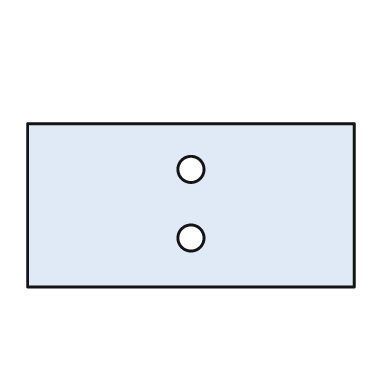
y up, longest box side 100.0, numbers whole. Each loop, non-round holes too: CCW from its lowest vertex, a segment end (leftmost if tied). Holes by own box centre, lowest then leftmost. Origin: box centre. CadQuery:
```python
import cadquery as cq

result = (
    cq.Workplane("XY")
    .moveTo(-50.0, -25.0)
    .lineTo(50.0, -25.0)
    .lineTo(50.0, 25.0)
    .lineTo(-50.0, 25.0)
    .close()
    .moveTo(0.0, -10.0)
    .circle(4.0)
    .moveTo(0.0, 11.0)
    .circle(4.0)
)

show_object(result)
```